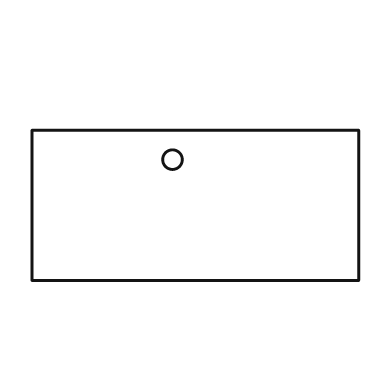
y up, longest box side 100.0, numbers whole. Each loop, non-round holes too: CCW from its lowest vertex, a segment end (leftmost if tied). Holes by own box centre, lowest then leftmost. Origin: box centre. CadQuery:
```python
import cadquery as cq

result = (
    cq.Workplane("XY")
    .moveTo(-50.0, -23.0)
    .lineTo(50.0, -23.0)
    .lineTo(50.0, 23.0)
    .lineTo(-50.0, 23.0)
    .close()
    .moveTo(-7.0, 14.0)
    .circle(3.0)
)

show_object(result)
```